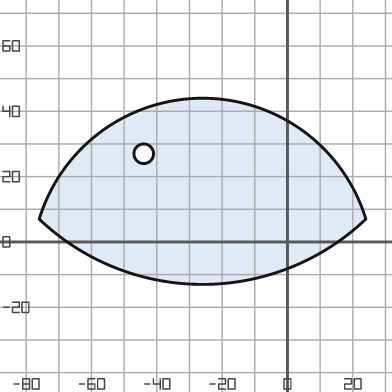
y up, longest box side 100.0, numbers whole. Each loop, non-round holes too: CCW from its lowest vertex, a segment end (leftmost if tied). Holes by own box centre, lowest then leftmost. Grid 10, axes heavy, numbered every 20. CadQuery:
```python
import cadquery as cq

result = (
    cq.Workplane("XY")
    .moveTo(-76.0, 7.0)
    .threePointArc((-26.0, -13.0), (24.0, 7.0))
    .threePointArc((-26.0, 44.0), (-76.0, 7.0))
    .close()
    .moveTo(-44.0, 27.0)
    .circle(3.0)
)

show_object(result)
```